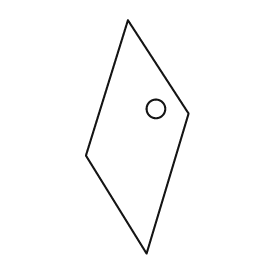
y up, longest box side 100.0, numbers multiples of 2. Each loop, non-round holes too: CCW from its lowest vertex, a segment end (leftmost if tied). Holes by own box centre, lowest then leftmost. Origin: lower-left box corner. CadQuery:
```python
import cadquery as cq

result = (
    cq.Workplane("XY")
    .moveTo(26.0, 0.0)
    .lineTo(44.0, 60.0)
    .lineTo(18.0, 100.0)
    .lineTo(0.0, 42.0)
    .close()
    .moveTo(30.0, 62.0)
    .circle(4.0)
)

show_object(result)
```